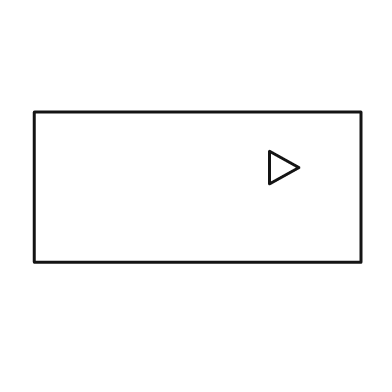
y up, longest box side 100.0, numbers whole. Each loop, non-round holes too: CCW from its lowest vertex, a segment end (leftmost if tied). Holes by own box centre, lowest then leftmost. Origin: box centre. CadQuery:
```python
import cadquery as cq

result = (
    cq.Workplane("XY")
    .moveTo(-50.0, -23.0)
    .lineTo(50.0, -23.0)
    .lineTo(50.0, 23.0)
    .lineTo(-50.0, 23.0)
    .close()
    .moveTo(22.0, 1.0)
    .lineTo(31.0, 6.0)
    .lineTo(22.0, 11.0)
    .close()
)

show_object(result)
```